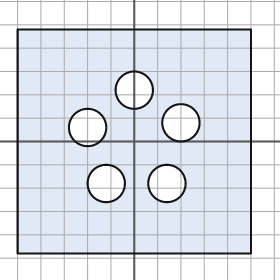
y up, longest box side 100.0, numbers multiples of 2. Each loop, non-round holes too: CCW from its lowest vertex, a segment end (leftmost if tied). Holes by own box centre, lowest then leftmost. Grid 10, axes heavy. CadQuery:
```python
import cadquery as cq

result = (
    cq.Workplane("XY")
    .moveTo(-50.0, -48.0)
    .lineTo(50.0, -48.0)
    .lineTo(50.0, 48.0)
    .lineTo(-50.0, 48.0)
    .close()
    .moveTo(-12.0, -18.0)
    .circle(8.0)
    .moveTo(14.0, -18.0)
    .circle(8.0)
    .moveTo(-20.0, 6.0)
    .circle(8.0)
    .moveTo(20.0, 8.0)
    .circle(8.0)
    .moveTo(0.0, 22.0)
    .circle(8.0)
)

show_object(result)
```